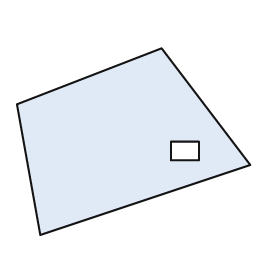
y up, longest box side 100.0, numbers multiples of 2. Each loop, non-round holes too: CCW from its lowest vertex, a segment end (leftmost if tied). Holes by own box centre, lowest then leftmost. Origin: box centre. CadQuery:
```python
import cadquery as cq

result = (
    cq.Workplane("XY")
    .moveTo(-40.0, -40.0)
    .lineTo(50.0, -10.0)
    .lineTo(12.0, 40.0)
    .lineTo(-50.0, 16.0)
    .close()
    .moveTo(16.0, -8.0)
    .lineTo(28.0, -8.0)
    .lineTo(28.0, 0.0)
    .lineTo(16.0, 0.0)
    .close()
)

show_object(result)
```